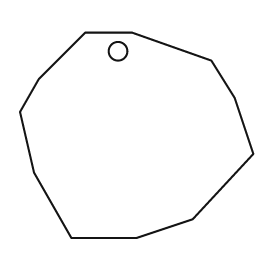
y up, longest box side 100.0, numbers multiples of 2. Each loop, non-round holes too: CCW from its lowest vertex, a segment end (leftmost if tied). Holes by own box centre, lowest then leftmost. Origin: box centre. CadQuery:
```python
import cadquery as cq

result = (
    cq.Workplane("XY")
    .moveTo(-28.0, -44.0)
    .lineTo(0.0, -44.0)
    .lineTo(24.0, -36.0)
    .lineTo(50.0, -8.0)
    .lineTo(42.0, 16.0)
    .lineTo(32.0, 32.0)
    .lineTo(-2.0, 44.0)
    .lineTo(-22.0, 44.0)
    .lineTo(-42.0, 24.0)
    .lineTo(-50.0, 10.0)
    .lineTo(-44.0, -16.0)
    .close()
    .moveTo(-8.0, 36.0)
    .circle(4.0)
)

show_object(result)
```